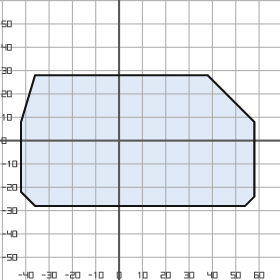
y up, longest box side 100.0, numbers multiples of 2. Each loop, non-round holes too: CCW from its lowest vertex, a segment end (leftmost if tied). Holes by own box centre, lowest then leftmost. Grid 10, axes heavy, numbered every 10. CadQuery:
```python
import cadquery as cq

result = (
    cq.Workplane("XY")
    .moveTo(-36.0, -28.0)
    .lineTo(54.0, -28.0)
    .lineTo(58.0, -24.0)
    .lineTo(58.0, 8.0)
    .lineTo(38.0, 28.0)
    .lineTo(-36.0, 28.0)
    .lineTo(-42.0, 8.0)
    .lineTo(-42.0, -22.0)
    .close()
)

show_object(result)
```